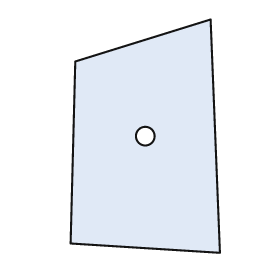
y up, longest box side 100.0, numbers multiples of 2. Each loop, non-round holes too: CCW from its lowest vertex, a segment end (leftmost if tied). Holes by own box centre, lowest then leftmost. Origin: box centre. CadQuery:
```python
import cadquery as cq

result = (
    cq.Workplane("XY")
    .moveTo(32.0, -50.0)
    .lineTo(28.0, 50.0)
    .lineTo(-30.0, 32.0)
    .lineTo(-32.0, -46.0)
    .close()
    .moveTo(0.0, 0.0)
    .circle(4.0)
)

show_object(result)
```